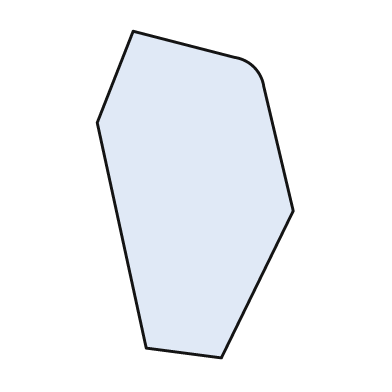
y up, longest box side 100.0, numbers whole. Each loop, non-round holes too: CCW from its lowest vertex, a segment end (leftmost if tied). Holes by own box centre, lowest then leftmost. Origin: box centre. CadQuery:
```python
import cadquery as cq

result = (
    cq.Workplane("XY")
    .moveTo(8.0, -50.0)
    .lineTo(30.0, -5.0)
    .lineTo(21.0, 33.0)
    .threePointArc((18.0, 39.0), (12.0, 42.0))
    .lineTo(-19.0, 50.0)
    .lineTo(-30.0, 22.0)
    .lineTo(-15.0, -47.0)
    .close()
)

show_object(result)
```